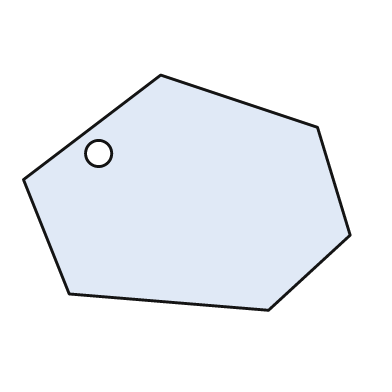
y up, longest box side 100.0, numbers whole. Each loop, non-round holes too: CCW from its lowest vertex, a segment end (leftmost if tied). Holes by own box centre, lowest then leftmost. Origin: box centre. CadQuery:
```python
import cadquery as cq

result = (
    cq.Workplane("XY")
    .moveTo(25.0, -36.0)
    .lineTo(50.0, -13.0)
    .lineTo(40.0, 20.0)
    .lineTo(-8.0, 36.0)
    .lineTo(-50.0, 4.0)
    .lineTo(-36.0, -31.0)
    .close()
    .moveTo(-27.0, 12.0)
    .circle(4.0)
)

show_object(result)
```